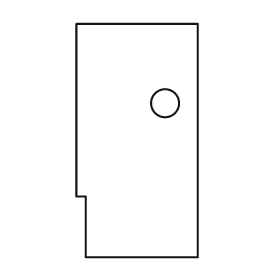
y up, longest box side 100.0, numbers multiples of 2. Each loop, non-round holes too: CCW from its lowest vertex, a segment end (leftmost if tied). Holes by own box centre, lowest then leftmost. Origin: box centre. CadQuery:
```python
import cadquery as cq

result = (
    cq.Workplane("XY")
    .moveTo(-22.0, -50.0)
    .lineTo(26.0, -50.0)
    .lineTo(26.0, 50.0)
    .lineTo(-26.0, 50.0)
    .lineTo(-26.0, -24.0)
    .lineTo(-22.0, -24.0)
    .close()
    .moveTo(12.0, 16.0)
    .circle(6.0)
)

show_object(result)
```